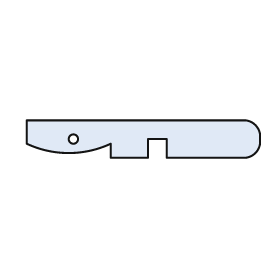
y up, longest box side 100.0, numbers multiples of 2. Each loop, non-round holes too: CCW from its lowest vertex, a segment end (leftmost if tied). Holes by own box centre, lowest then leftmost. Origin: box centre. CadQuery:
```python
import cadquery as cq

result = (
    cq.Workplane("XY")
    .moveTo(-14.0, -8.0)
    .lineTo(2.0, -8.0)
    .lineTo(2.0, 0.0)
    .lineTo(10.0, 0.0)
    .lineTo(10.0, -8.0)
    .lineTo(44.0, -8.0)
    .threePointArc((48.0, -6.0), (50.0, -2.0))
    .lineTo(50.0, 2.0)
    .threePointArc((48.0, 6.0), (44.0, 8.0))
    .lineTo(-50.0, 8.0)
    .lineTo(-50.0, -2.0)
    .threePointArc((-32.0, -6.0), (-14.0, -2.0))
    .close()
    .moveTo(-30.0, 0.0)
    .circle(2.0)
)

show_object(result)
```